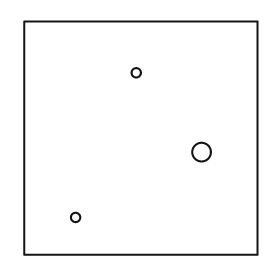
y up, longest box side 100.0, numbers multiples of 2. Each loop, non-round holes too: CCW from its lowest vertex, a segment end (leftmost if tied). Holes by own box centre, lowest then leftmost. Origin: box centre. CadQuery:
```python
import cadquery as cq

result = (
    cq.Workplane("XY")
    .moveTo(-50.0, -50.0)
    .lineTo(50.0, -50.0)
    .lineTo(50.0, 50.0)
    .lineTo(-50.0, 50.0)
    .close()
    .moveTo(-28.0, -34.0)
    .circle(2.0)
    .moveTo(26.0, -6.0)
    .circle(4.0)
    .moveTo(-2.0, 28.0)
    .circle(2.0)
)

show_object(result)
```